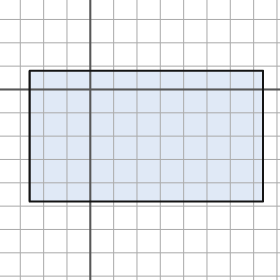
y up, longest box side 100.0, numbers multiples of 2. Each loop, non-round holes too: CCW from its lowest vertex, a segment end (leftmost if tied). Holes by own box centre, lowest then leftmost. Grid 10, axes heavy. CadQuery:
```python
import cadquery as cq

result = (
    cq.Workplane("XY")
    .moveTo(-26.0, -48.0)
    .lineTo(74.0, -48.0)
    .lineTo(74.0, 8.0)
    .lineTo(-26.0, 8.0)
    .close()
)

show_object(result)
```